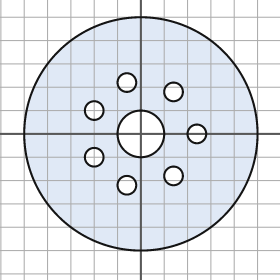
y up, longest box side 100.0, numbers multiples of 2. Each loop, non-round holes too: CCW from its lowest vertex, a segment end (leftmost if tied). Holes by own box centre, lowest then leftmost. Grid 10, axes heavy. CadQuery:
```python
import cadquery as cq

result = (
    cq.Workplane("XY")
    .moveTo(0.0, 0.0)
    .circle(50.0)
    .moveTo(-6.0, -22.0)
    .circle(4.0)
    .moveTo(14.0, -18.0)
    .circle(4.0)
    .moveTo(-20.0, -10.0)
    .circle(4.0)
    .moveTo(0.0, 0.0)
    .circle(10.0)
    .moveTo(24.0, 0.0)
    .circle(4.0)
    .moveTo(-20.0, 10.0)
    .circle(4.0)
    .moveTo(14.0, 18.0)
    .circle(4.0)
    .moveTo(-6.0, 22.0)
    .circle(4.0)
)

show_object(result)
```